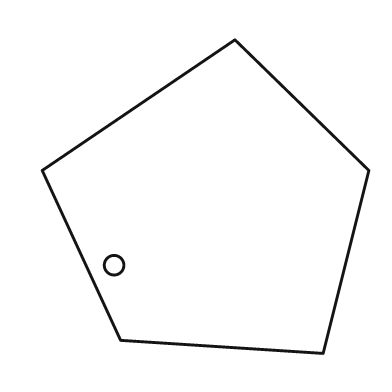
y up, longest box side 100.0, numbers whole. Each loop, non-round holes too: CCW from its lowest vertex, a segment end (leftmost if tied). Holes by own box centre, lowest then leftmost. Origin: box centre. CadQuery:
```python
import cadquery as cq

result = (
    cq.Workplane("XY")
    .moveTo(36.0, -48.0)
    .lineTo(50.0, 8.0)
    .lineTo(9.0, 48.0)
    .lineTo(-50.0, 8.0)
    .lineTo(-26.0, -44.0)
    .close()
    .moveTo(-28.0, -21.0)
    .circle(3.0)
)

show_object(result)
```